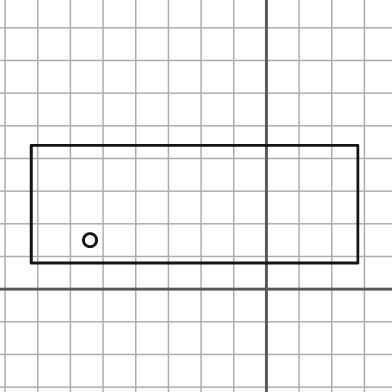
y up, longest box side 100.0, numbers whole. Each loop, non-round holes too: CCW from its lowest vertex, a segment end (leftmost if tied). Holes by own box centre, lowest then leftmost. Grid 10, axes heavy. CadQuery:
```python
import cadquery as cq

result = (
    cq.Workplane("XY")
    .moveTo(-72.0, 8.0)
    .lineTo(28.0, 8.0)
    .lineTo(28.0, 44.0)
    .lineTo(-72.0, 44.0)
    .close()
    .moveTo(-54.0, 15.0)
    .circle(2.0)
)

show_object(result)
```